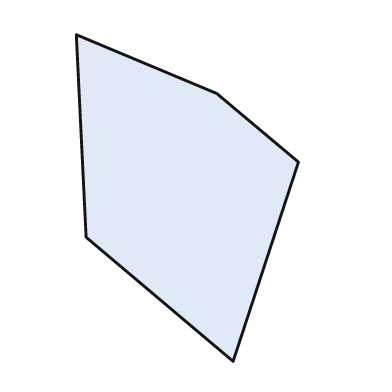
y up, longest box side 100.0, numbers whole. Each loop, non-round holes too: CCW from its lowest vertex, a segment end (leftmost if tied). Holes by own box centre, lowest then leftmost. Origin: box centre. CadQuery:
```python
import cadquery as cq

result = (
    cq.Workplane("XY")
    .moveTo(14.0, -50.0)
    .lineTo(34.0, 11.0)
    .lineTo(9.0, 32.0)
    .lineTo(-34.0, 50.0)
    .lineTo(-31.0, -12.0)
    .close()
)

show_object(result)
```